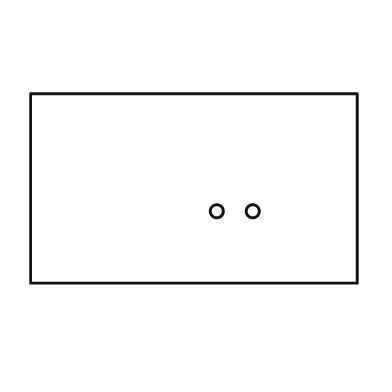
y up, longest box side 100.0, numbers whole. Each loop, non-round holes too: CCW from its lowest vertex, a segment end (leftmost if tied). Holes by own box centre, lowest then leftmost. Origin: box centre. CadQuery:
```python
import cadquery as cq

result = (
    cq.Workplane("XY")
    .moveTo(-50.0, -29.0)
    .lineTo(50.0, -29.0)
    .lineTo(50.0, 29.0)
    .lineTo(-50.0, 29.0)
    .close()
    .moveTo(7.0, -7.0)
    .circle(2.0)
    .moveTo(18.0, -7.0)
    .circle(2.0)
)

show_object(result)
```